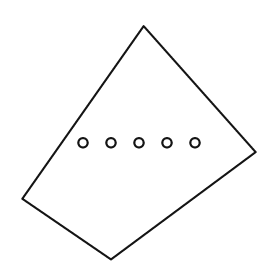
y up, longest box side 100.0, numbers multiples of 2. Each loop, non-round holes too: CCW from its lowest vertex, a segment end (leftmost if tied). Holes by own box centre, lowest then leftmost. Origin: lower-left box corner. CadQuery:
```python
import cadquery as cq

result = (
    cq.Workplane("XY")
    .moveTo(38.0, 0.0)
    .lineTo(100.0, 46.0)
    .lineTo(52.0, 100.0)
    .lineTo(0.0, 26.0)
    .close()
    .moveTo(26.0, 50.0)
    .circle(2.0)
    .moveTo(38.0, 50.0)
    .circle(2.0)
    .moveTo(50.0, 50.0)
    .circle(2.0)
    .moveTo(62.0, 50.0)
    .circle(2.0)
    .moveTo(74.0, 50.0)
    .circle(2.0)
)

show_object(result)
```